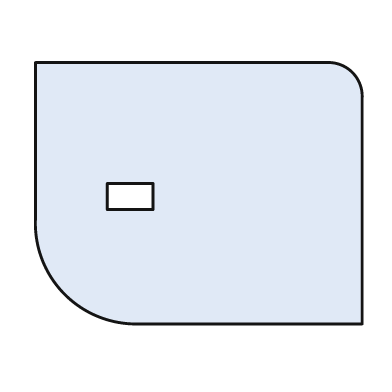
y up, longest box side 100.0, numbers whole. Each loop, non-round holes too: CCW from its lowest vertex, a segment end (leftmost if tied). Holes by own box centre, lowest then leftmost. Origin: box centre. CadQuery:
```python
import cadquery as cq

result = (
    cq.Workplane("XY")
    .moveTo(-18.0, -40.0)
    .lineTo(50.0, -40.0)
    .lineTo(50.0, 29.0)
    .threePointArc((47.0, 37.0), (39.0, 40.0))
    .lineTo(-50.0, 40.0)
    .lineTo(-50.0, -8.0)
    .threePointArc((-41.0, -31.0), (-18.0, -40.0))
    .close()
    .moveTo(-28.0, -5.0)
    .lineTo(-14.0, -5.0)
    .lineTo(-14.0, 3.0)
    .lineTo(-28.0, 3.0)
    .close()
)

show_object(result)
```